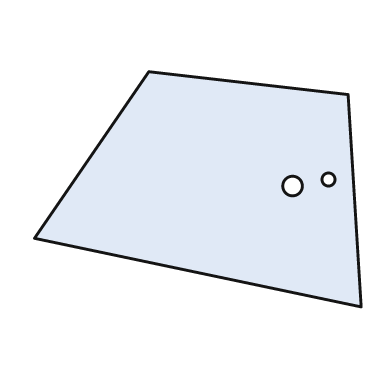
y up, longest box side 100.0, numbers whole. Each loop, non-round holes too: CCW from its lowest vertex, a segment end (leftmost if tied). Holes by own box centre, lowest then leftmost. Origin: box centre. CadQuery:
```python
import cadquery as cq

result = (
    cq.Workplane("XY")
    .moveTo(50.0, -36.0)
    .lineTo(46.0, 29.0)
    .lineTo(-15.0, 36.0)
    .lineTo(-50.0, -15.0)
    .close()
    .moveTo(29.0, 1.0)
    .circle(3.0)
    .moveTo(40.0, 3.0)
    .circle(2.0)
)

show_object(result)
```